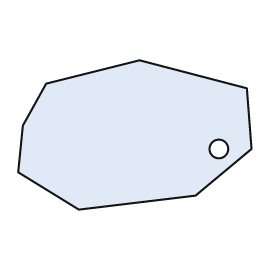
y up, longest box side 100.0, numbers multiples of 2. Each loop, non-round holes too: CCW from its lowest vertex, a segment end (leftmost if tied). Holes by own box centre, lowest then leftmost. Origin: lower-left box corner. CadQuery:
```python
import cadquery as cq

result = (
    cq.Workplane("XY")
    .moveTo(26.0, 0.0)
    .lineTo(76.0, 6.0)
    .lineTo(100.0, 26.0)
    .lineTo(98.0, 52.0)
    .lineTo(52.0, 64.0)
    .lineTo(12.0, 54.0)
    .lineTo(2.0, 36.0)
    .lineTo(0.0, 16.0)
    .close()
    .moveTo(86.0, 26.0)
    .circle(4.0)
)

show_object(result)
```